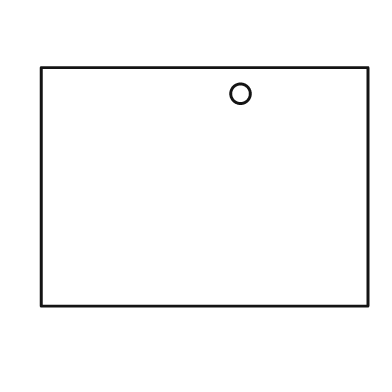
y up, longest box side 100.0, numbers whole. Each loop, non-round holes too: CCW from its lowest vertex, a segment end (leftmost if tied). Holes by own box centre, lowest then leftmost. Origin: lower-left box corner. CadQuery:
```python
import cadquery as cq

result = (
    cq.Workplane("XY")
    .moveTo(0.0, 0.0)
    .lineTo(100.0, 0.0)
    .lineTo(100.0, 73.0)
    .lineTo(0.0, 73.0)
    .close()
    .moveTo(61.0, 65.0)
    .circle(3.0)
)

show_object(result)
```